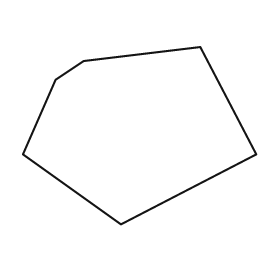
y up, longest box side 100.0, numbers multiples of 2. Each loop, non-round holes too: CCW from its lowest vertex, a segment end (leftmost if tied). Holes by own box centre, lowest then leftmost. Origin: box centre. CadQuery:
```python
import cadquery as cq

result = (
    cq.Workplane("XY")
    .moveTo(-8.0, -38.0)
    .lineTo(50.0, -8.0)
    .lineTo(26.0, 38.0)
    .lineTo(-24.0, 32.0)
    .lineTo(-36.0, 24.0)
    .lineTo(-50.0, -8.0)
    .close()
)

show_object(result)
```